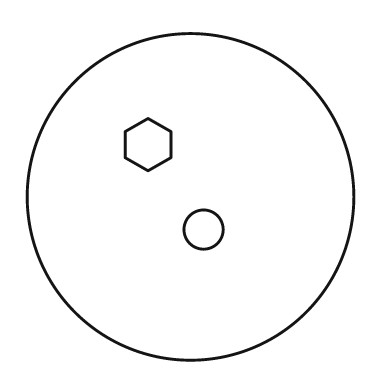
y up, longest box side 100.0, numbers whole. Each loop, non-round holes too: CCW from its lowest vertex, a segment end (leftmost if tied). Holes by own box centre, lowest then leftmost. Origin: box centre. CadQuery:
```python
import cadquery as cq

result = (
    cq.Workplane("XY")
    .moveTo(0.0, 0.0)
    .circle(50.0)
    .moveTo(4.0, -10.0)
    .circle(6.0)
    .moveTo(-13.0, 8.0)
    .lineTo(-6.0, 12.0)
    .lineTo(-6.0, 20.0)
    .lineTo(-13.0, 24.0)
    .lineTo(-20.0, 20.0)
    .lineTo(-20.0, 12.0)
    .close()
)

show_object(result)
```